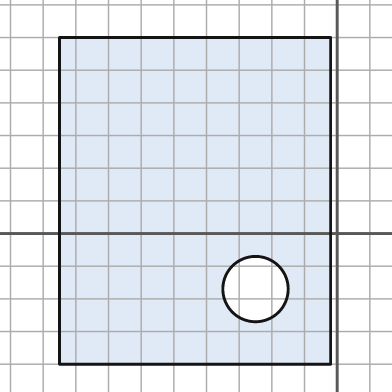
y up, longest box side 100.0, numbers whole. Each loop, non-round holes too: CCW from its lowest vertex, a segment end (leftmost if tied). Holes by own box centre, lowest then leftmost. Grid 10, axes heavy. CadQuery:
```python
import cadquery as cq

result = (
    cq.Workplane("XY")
    .moveTo(-85.0, -40.0)
    .lineTo(-2.0, -40.0)
    .lineTo(-2.0, 60.0)
    .lineTo(-85.0, 60.0)
    .close()
    .moveTo(-25.0, -17.0)
    .circle(10.0)
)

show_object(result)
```